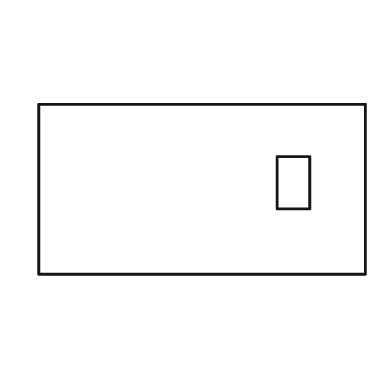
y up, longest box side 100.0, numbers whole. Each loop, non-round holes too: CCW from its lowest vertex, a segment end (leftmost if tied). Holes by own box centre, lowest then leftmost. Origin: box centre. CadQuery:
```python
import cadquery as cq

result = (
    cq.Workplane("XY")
    .moveTo(-50.0, -26.0)
    .lineTo(50.0, -26.0)
    .lineTo(50.0, 26.0)
    .lineTo(-50.0, 26.0)
    .close()
    .moveTo(23.0, -6.0)
    .lineTo(33.0, -6.0)
    .lineTo(33.0, 10.0)
    .lineTo(23.0, 10.0)
    .close()
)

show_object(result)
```